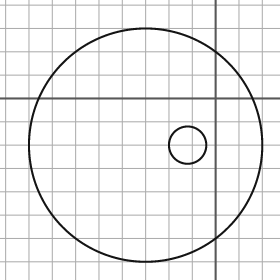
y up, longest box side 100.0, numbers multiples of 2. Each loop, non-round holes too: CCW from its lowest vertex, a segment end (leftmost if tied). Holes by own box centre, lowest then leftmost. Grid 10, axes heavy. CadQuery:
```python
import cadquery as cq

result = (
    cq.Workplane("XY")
    .moveTo(-30.0, -20.0)
    .circle(50.0)
    .moveTo(-12.0, -20.0)
    .circle(8.0)
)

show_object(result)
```